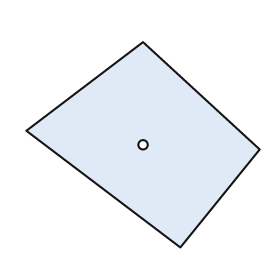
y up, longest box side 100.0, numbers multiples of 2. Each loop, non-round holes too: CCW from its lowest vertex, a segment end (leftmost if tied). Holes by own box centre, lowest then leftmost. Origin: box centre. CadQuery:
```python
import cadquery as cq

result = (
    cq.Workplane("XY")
    .moveTo(16.0, -44.0)
    .lineTo(50.0, -2.0)
    .lineTo(0.0, 44.0)
    .lineTo(-50.0, 6.0)
    .close()
    .moveTo(0.0, 0.0)
    .circle(2.0)
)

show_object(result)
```